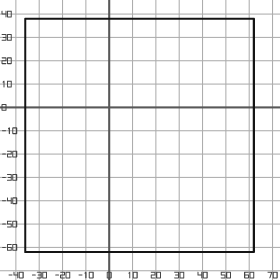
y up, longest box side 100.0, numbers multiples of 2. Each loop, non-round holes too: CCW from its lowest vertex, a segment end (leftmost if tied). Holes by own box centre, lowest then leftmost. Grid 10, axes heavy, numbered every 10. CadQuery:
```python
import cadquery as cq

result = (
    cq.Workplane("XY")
    .moveTo(-36.0, -62.0)
    .lineTo(62.0, -62.0)
    .lineTo(62.0, 38.0)
    .lineTo(-36.0, 38.0)
    .close()
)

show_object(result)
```